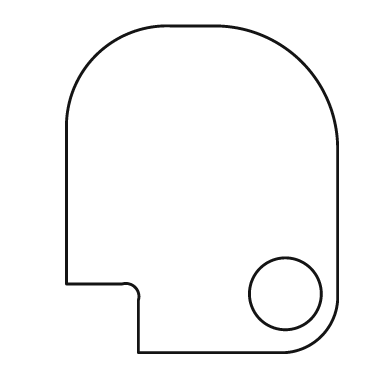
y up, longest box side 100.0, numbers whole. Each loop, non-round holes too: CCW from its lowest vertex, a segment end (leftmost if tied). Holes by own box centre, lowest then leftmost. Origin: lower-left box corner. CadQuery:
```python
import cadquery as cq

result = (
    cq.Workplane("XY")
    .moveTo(22.0, 0.0)
    .lineTo(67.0, 0.0)
    .threePointArc((78.0, 5.0), (83.0, 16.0))
    .lineTo(83.0, 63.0)
    .threePointArc((72.0, 89.0), (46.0, 100.0))
    .lineTo(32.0, 100.0)
    .threePointArc((9.0, 91.0), (0.0, 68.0))
    .lineTo(0.0, 21.0)
    .lineTo(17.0, 21.0)
    .threePointArc((21.0, 20.0), (22.0, 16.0))
    .close()
    .moveTo(67.0, 18.0)
    .circle(11.0)
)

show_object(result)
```